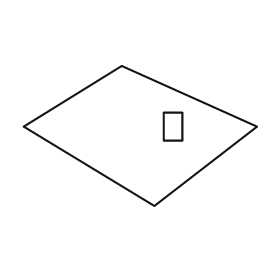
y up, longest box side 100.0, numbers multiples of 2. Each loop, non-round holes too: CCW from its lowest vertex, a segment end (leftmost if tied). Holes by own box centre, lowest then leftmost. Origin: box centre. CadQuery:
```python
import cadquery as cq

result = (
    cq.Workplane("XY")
    .moveTo(6.0, -30.0)
    .lineTo(50.0, 4.0)
    .lineTo(-8.0, 30.0)
    .lineTo(-50.0, 4.0)
    .close()
    .moveTo(10.0, -2.0)
    .lineTo(18.0, -2.0)
    .lineTo(18.0, 10.0)
    .lineTo(10.0, 10.0)
    .close()
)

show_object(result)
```